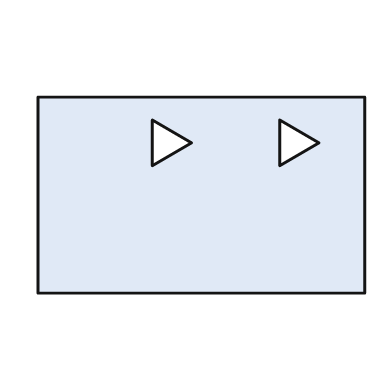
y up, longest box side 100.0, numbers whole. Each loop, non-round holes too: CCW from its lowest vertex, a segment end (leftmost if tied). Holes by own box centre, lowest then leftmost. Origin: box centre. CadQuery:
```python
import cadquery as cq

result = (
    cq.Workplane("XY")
    .moveTo(-50.0, -30.0)
    .lineTo(50.0, -30.0)
    .lineTo(50.0, 30.0)
    .lineTo(-50.0, 30.0)
    .close()
    .moveTo(-15.0, 9.0)
    .lineTo(-3.0, 16.0)
    .lineTo(-15.0, 23.0)
    .close()
    .moveTo(24.0, 9.0)
    .lineTo(36.0, 16.0)
    .lineTo(24.0, 23.0)
    .close()
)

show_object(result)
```